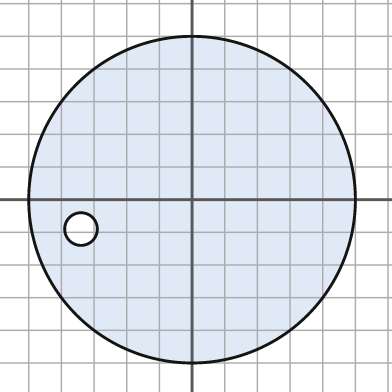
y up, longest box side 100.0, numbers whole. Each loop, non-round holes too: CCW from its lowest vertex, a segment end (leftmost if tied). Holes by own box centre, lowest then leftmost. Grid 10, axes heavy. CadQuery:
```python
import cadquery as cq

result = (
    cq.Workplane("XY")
    .moveTo(0.0, 0.0)
    .circle(50.0)
    .moveTo(-34.0, -9.0)
    .circle(5.0)
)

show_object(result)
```